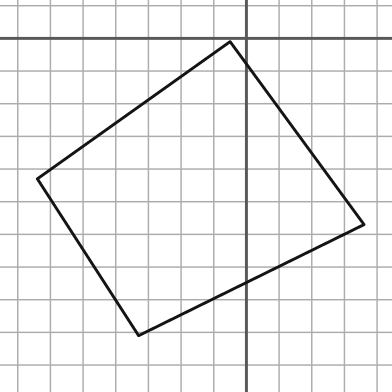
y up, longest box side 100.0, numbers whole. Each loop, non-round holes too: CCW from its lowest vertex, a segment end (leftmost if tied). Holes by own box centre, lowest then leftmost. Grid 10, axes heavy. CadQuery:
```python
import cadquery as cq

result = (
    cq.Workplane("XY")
    .moveTo(-33.0, -91.0)
    .lineTo(36.0, -57.0)
    .lineTo(-5.0, -1.0)
    .lineTo(-64.0, -43.0)
    .close()
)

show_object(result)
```